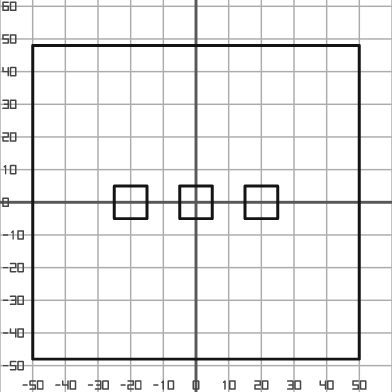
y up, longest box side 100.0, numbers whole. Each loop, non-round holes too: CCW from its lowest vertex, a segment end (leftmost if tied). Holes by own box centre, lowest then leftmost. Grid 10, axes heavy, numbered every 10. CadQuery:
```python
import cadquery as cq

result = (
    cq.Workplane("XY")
    .moveTo(-50.0, -48.0)
    .lineTo(50.0, -48.0)
    .lineTo(50.0, 48.0)
    .lineTo(-50.0, 48.0)
    .close()
    .moveTo(-25.0, -5.0)
    .lineTo(-15.0, -5.0)
    .lineTo(-15.0, 5.0)
    .lineTo(-25.0, 5.0)
    .close()
    .moveTo(-5.0, -5.0)
    .lineTo(5.0, -5.0)
    .lineTo(5.0, 5.0)
    .lineTo(-5.0, 5.0)
    .close()
    .moveTo(15.0, -5.0)
    .lineTo(25.0, -5.0)
    .lineTo(25.0, 5.0)
    .lineTo(15.0, 5.0)
    .close()
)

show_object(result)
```